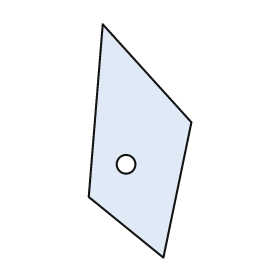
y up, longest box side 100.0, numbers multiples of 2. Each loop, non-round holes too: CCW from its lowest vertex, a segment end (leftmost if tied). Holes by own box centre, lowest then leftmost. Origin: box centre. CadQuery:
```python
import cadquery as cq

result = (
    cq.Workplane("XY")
    .moveTo(10.0, -50.0)
    .lineTo(22.0, 8.0)
    .lineTo(-16.0, 50.0)
    .lineTo(-22.0, -24.0)
    .close()
    .moveTo(-6.0, -10.0)
    .circle(4.0)
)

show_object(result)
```